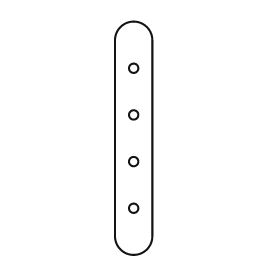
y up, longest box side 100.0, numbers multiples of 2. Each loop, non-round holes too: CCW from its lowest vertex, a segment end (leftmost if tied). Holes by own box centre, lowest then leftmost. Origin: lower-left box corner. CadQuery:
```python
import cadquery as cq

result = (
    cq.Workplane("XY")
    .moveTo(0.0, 8.0)
    .threePointArc((8.0, 0.0), (16.0, 8.0))
    .lineTo(16.0, 92.0)
    .threePointArc((8.0, 100.0), (0.0, 92.0))
    .close()
    .moveTo(8.0, 20.0)
    .circle(2.0)
    .moveTo(8.0, 40.0)
    .circle(2.0)
    .moveTo(8.0, 60.0)
    .circle(2.0)
    .moveTo(8.0, 80.0)
    .circle(2.0)
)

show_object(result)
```